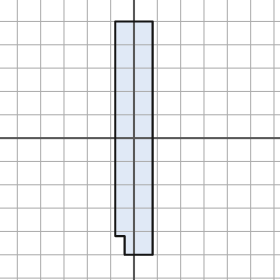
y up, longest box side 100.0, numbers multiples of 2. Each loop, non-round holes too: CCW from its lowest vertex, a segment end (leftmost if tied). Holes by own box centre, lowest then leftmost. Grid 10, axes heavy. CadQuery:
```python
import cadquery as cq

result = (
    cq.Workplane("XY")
    .moveTo(-4.0, -50.0)
    .lineTo(8.0, -50.0)
    .lineTo(8.0, 50.0)
    .lineTo(-8.0, 50.0)
    .lineTo(-8.0, -42.0)
    .lineTo(-4.0, -42.0)
    .close()
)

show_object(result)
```